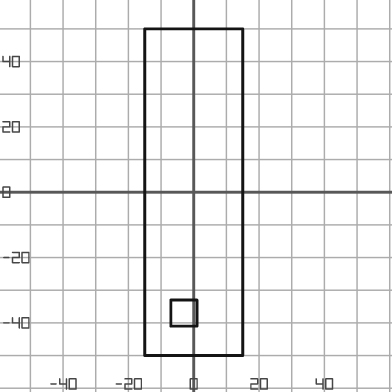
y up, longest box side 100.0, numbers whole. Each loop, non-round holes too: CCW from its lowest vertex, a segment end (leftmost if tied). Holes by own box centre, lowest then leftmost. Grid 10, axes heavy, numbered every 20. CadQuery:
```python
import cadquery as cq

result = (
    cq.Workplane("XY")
    .moveTo(-15.0, -50.0)
    .lineTo(15.0, -50.0)
    .lineTo(15.0, 50.0)
    .lineTo(-15.0, 50.0)
    .close()
    .moveTo(-7.0, -41.0)
    .lineTo(1.0, -41.0)
    .lineTo(1.0, -33.0)
    .lineTo(-7.0, -33.0)
    .close()
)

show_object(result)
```